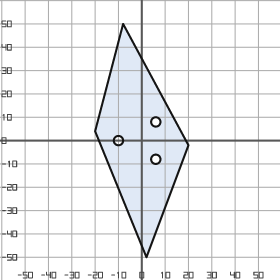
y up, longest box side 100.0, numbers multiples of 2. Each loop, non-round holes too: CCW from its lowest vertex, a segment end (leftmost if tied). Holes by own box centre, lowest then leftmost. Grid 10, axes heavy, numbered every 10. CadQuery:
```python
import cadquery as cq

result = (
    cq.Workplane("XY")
    .moveTo(2.0, -50.0)
    .lineTo(20.0, -2.0)
    .lineTo(-8.0, 50.0)
    .lineTo(-20.0, 4.0)
    .close()
    .moveTo(6.0, -8.0)
    .circle(2.0)
    .moveTo(-10.0, 0.0)
    .circle(2.0)
    .moveTo(6.0, 8.0)
    .circle(2.0)
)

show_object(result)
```